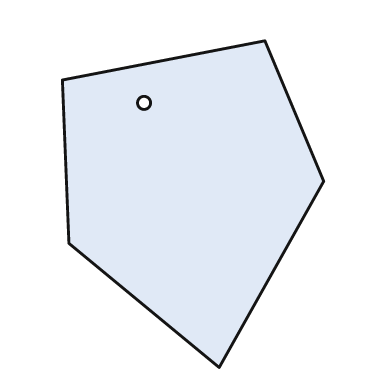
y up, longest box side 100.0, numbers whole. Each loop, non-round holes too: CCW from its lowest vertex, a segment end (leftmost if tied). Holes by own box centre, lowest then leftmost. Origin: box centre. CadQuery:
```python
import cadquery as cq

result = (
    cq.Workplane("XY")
    .moveTo(8.0, -50.0)
    .lineTo(40.0, 7.0)
    .lineTo(22.0, 50.0)
    .lineTo(-40.0, 38.0)
    .lineTo(-38.0, -12.0)
    .close()
    .moveTo(-15.0, 31.0)
    .circle(2.0)
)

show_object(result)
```